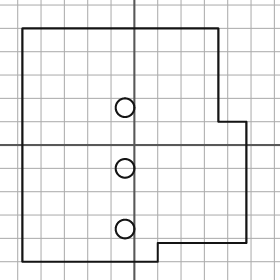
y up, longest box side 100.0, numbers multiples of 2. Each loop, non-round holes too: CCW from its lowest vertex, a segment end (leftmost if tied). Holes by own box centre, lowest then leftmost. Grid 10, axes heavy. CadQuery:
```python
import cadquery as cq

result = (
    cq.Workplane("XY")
    .moveTo(-48.0, -50.0)
    .lineTo(10.0, -50.0)
    .lineTo(10.0, -42.0)
    .lineTo(48.0, -42.0)
    .lineTo(48.0, 10.0)
    .lineTo(36.0, 10.0)
    .lineTo(36.0, 50.0)
    .lineTo(-48.0, 50.0)
    .close()
    .moveTo(-4.0, -36.0)
    .circle(4.0)
    .moveTo(-4.0, -10.0)
    .circle(4.0)
    .moveTo(-4.0, 16.0)
    .circle(4.0)
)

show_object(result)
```